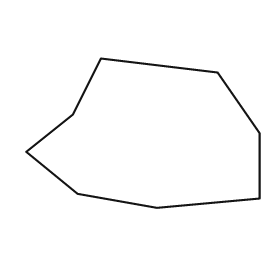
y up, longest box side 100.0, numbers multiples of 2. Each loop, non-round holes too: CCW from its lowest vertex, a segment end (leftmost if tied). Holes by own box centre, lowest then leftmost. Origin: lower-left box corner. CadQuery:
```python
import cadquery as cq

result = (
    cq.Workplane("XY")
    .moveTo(56.0, 0.0)
    .lineTo(100.0, 4.0)
    .lineTo(100.0, 32.0)
    .lineTo(82.0, 58.0)
    .lineTo(32.0, 64.0)
    .lineTo(20.0, 40.0)
    .lineTo(0.0, 24.0)
    .lineTo(22.0, 6.0)
    .close()
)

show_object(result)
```